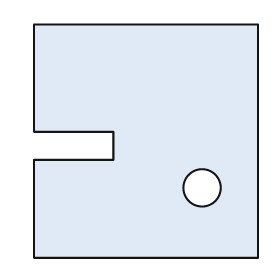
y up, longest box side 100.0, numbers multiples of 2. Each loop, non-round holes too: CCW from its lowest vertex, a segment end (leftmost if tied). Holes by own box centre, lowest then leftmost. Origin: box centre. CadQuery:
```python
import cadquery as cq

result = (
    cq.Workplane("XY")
    .moveTo(-48.0, -50.0)
    .lineTo(48.0, -50.0)
    .lineTo(48.0, 50.0)
    .lineTo(-48.0, 50.0)
    .lineTo(-48.0, 4.0)
    .lineTo(-14.0, 4.0)
    .lineTo(-14.0, -8.0)
    .lineTo(-48.0, -8.0)
    .close()
    .moveTo(24.0, -20.0)
    .circle(8.0)
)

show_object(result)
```